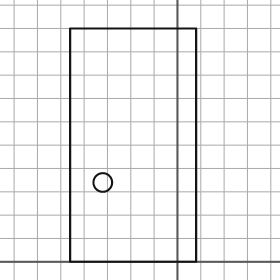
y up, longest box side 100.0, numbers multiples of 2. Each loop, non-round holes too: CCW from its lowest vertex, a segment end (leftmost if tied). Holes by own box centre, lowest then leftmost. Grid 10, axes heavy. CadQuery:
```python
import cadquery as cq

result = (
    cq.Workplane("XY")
    .moveTo(-46.0, 0.0)
    .lineTo(8.0, 0.0)
    .lineTo(8.0, 100.0)
    .lineTo(-46.0, 100.0)
    .close()
    .moveTo(-32.0, 34.0)
    .circle(4.0)
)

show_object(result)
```